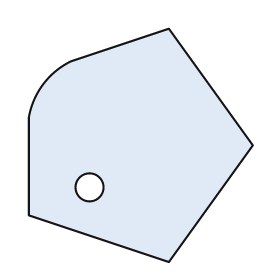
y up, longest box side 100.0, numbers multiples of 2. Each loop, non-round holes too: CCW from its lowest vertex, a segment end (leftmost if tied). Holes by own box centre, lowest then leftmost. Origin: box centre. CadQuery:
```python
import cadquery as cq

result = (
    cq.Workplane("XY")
    .moveTo(12.0, -50.0)
    .lineTo(48.0, 0.0)
    .lineTo(12.0, 50.0)
    .lineTo(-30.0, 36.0)
    .threePointArc((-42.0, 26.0), (-48.0, 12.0))
    .lineTo(-48.0, -30.0)
    .close()
    .moveTo(-22.0, -18.0)
    .circle(6.0)
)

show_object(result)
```